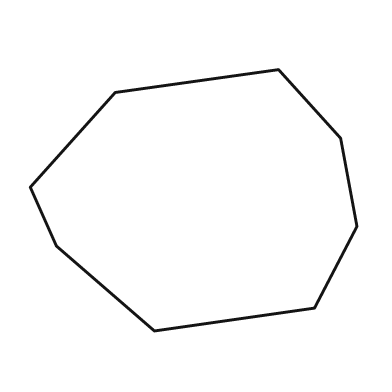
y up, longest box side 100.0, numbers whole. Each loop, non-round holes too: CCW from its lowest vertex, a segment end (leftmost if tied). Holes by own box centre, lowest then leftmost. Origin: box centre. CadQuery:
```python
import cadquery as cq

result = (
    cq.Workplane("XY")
    .moveTo(-12.0, -40.0)
    .lineTo(37.0, -33.0)
    .lineTo(50.0, -8.0)
    .lineTo(45.0, 19.0)
    .lineTo(26.0, 40.0)
    .lineTo(-24.0, 33.0)
    .lineTo(-50.0, 4.0)
    .lineTo(-42.0, -14.0)
    .close()
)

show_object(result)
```